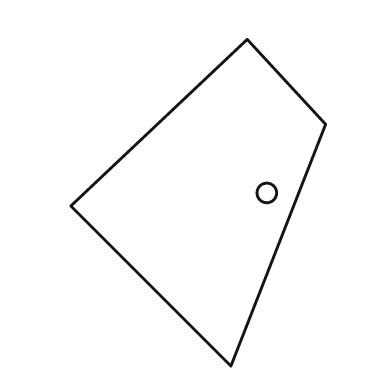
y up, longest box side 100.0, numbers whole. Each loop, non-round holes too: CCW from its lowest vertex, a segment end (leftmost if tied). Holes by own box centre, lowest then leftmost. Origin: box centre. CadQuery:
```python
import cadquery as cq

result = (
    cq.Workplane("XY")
    .moveTo(10.0, -50.0)
    .lineTo(39.0, 24.0)
    .lineTo(15.0, 50.0)
    .lineTo(-39.0, -1.0)
    .close()
    .moveTo(21.0, 3.0)
    .circle(3.0)
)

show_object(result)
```